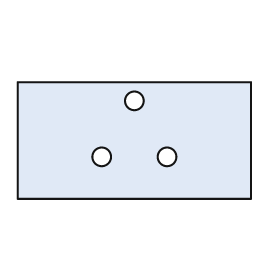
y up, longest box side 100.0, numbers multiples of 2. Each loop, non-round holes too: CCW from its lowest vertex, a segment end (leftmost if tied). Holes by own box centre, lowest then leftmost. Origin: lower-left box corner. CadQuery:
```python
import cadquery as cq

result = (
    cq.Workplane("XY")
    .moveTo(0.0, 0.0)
    .lineTo(100.0, 0.0)
    .lineTo(100.0, 50.0)
    .lineTo(0.0, 50.0)
    .close()
    .moveTo(36.0, 18.0)
    .circle(4.0)
    .moveTo(64.0, 18.0)
    .circle(4.0)
    .moveTo(50.0, 42.0)
    .circle(4.0)
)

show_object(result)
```